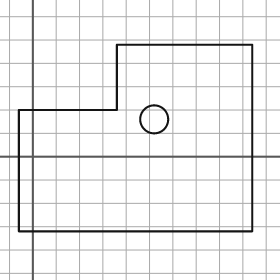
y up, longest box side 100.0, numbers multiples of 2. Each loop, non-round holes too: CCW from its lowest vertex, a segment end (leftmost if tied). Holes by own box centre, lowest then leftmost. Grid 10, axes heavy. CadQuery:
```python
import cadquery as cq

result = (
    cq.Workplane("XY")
    .moveTo(-6.0, -32.0)
    .lineTo(94.0, -32.0)
    .lineTo(94.0, 48.0)
    .lineTo(36.0, 48.0)
    .lineTo(36.0, 20.0)
    .lineTo(-6.0, 20.0)
    .close()
    .moveTo(52.0, 16.0)
    .circle(6.0)
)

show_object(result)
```